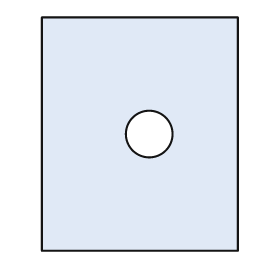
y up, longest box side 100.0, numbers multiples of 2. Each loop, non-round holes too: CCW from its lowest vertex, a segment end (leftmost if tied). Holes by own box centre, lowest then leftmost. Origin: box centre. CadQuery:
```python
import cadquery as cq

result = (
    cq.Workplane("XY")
    .moveTo(-42.0, -50.0)
    .lineTo(42.0, -50.0)
    .lineTo(42.0, 50.0)
    .lineTo(-42.0, 50.0)
    .close()
    .moveTo(4.0, 0.0)
    .circle(10.0)
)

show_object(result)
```